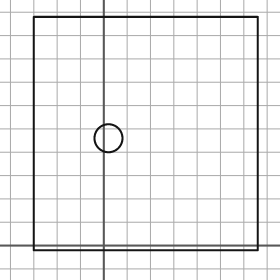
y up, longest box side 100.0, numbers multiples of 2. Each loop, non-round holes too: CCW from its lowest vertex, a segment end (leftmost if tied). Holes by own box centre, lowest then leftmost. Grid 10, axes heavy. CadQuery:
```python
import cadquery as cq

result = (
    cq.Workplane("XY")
    .moveTo(-30.0, -2.0)
    .lineTo(66.0, -2.0)
    .lineTo(66.0, 98.0)
    .lineTo(-30.0, 98.0)
    .close()
    .moveTo(2.0, 46.0)
    .circle(6.0)
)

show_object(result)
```